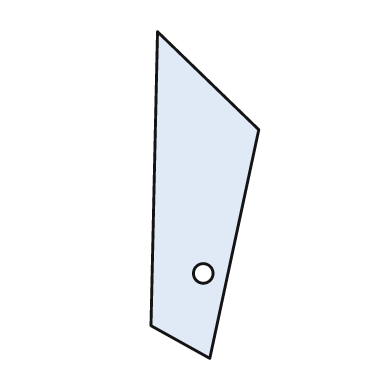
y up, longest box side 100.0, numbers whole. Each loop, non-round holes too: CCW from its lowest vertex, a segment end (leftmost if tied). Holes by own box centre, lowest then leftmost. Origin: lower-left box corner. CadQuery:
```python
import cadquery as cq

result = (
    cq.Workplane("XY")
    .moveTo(18.0, 0.0)
    .lineTo(33.0, 70.0)
    .lineTo(2.0, 100.0)
    .lineTo(0.0, 10.0)
    .close()
    .moveTo(16.0, 26.0)
    .circle(3.0)
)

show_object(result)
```